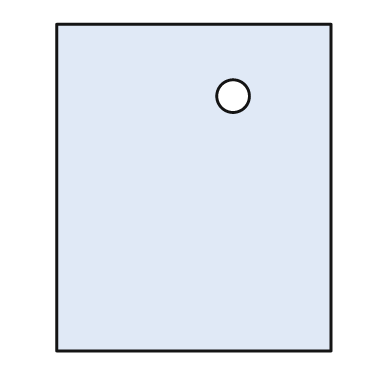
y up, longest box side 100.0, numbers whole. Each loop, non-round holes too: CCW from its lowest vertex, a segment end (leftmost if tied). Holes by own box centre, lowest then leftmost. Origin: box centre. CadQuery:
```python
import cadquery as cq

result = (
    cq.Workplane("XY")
    .moveTo(-42.0, -50.0)
    .lineTo(42.0, -50.0)
    .lineTo(42.0, 50.0)
    .lineTo(-42.0, 50.0)
    .close()
    .moveTo(12.0, 28.0)
    .circle(5.0)
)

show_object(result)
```